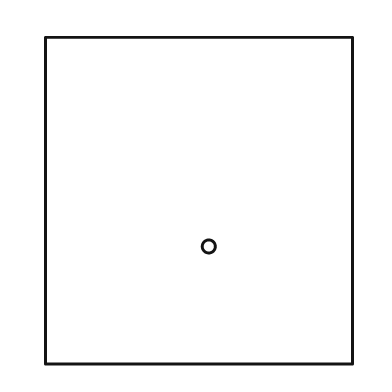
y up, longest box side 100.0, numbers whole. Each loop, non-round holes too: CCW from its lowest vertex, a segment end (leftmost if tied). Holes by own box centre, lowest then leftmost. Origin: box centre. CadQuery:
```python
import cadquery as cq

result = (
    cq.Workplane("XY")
    .moveTo(-47.0, -50.0)
    .lineTo(47.0, -50.0)
    .lineTo(47.0, 50.0)
    .lineTo(-47.0, 50.0)
    .close()
    .moveTo(3.0, -14.0)
    .circle(2.0)
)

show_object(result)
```